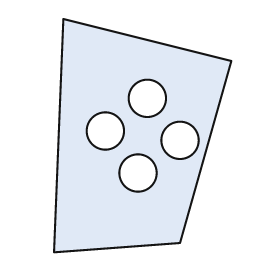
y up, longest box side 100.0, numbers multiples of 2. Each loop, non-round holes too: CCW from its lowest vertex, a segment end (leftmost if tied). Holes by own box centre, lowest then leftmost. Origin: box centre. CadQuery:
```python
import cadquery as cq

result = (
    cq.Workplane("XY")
    .moveTo(-38.0, -50.0)
    .lineTo(16.0, -46.0)
    .lineTo(38.0, 32.0)
    .lineTo(-34.0, 50.0)
    .close()
    .moveTo(-2.0, -16.0)
    .circle(8.0)
    .moveTo(16.0, -2.0)
    .circle(8.0)
    .moveTo(-16.0, 2.0)
    .circle(8.0)
    .moveTo(2.0, 16.0)
    .circle(8.0)
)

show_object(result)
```